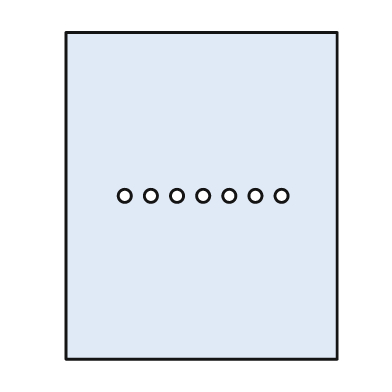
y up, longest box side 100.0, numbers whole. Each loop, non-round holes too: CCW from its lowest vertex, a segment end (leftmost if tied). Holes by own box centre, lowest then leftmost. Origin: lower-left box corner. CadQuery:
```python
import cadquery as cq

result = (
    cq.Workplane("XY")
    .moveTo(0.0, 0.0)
    .lineTo(83.0, 0.0)
    .lineTo(83.0, 100.0)
    .lineTo(0.0, 100.0)
    .close()
    .moveTo(18.0, 50.0)
    .circle(2.0)
    .moveTo(26.0, 50.0)
    .circle(2.0)
    .moveTo(34.0, 50.0)
    .circle(2.0)
    .moveTo(42.0, 50.0)
    .circle(2.0)
    .moveTo(50.0, 50.0)
    .circle(2.0)
    .moveTo(58.0, 50.0)
    .circle(2.0)
    .moveTo(66.0, 50.0)
    .circle(2.0)
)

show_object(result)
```